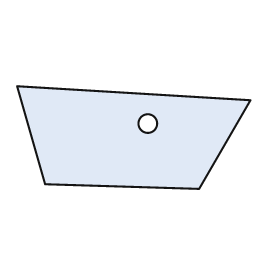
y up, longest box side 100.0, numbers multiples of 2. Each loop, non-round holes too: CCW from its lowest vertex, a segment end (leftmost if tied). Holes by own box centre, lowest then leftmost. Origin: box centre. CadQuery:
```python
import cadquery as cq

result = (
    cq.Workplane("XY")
    .moveTo(28.0, -22.0)
    .lineTo(50.0, 16.0)
    .lineTo(-50.0, 22.0)
    .lineTo(-38.0, -20.0)
    .close()
    .moveTo(6.0, 6.0)
    .circle(4.0)
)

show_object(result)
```